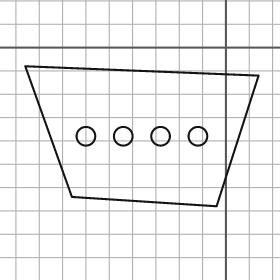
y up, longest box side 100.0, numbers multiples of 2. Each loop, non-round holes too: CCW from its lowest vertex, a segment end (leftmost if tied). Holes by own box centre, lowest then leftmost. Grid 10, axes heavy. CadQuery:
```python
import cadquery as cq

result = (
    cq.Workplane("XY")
    .moveTo(-4.0, -68.0)
    .lineTo(14.0, -12.0)
    .lineTo(-86.0, -8.0)
    .lineTo(-66.0, -64.0)
    .close()
    .moveTo(-60.0, -38.0)
    .circle(4.0)
    .moveTo(-44.0, -38.0)
    .circle(4.0)
    .moveTo(-28.0, -38.0)
    .circle(4.0)
    .moveTo(-12.0, -38.0)
    .circle(4.0)
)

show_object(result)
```